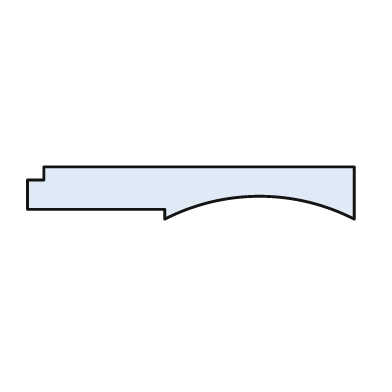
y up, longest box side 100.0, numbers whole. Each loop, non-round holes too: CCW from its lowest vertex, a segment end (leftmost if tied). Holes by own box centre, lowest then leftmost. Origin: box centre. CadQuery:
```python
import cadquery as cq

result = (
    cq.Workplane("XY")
    .moveTo(-8.0, -8.0)
    .threePointArc((21.0, -1.0), (50.0, -8.0))
    .lineTo(50.0, 8.0)
    .lineTo(-45.0, 8.0)
    .lineTo(-45.0, 4.0)
    .lineTo(-50.0, 4.0)
    .lineTo(-50.0, -5.0)
    .lineTo(-8.0, -5.0)
    .close()
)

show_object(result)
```